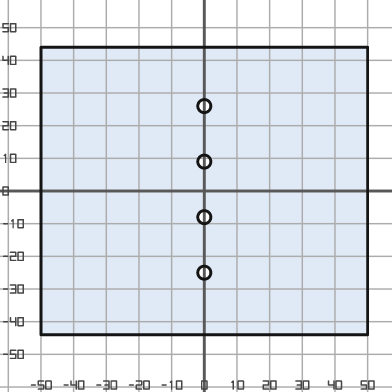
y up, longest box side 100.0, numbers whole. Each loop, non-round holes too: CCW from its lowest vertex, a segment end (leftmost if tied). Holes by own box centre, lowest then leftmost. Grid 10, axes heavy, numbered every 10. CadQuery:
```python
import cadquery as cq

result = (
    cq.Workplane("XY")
    .moveTo(-50.0, -44.0)
    .lineTo(50.0, -44.0)
    .lineTo(50.0, 44.0)
    .lineTo(-50.0, 44.0)
    .close()
    .moveTo(0.0, -25.0)
    .circle(2.0)
    .moveTo(0.0, -8.0)
    .circle(2.0)
    .moveTo(0.0, 9.0)
    .circle(2.0)
    .moveTo(0.0, 26.0)
    .circle(2.0)
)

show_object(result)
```